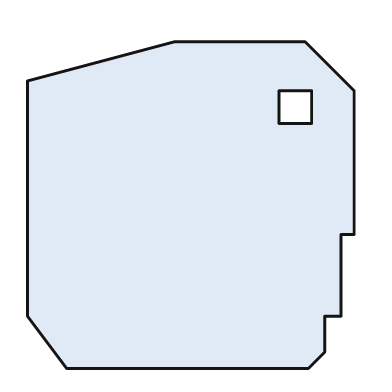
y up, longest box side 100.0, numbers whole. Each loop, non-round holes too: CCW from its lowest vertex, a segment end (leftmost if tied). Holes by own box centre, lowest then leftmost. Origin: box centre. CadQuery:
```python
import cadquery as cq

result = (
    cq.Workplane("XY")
    .moveTo(-38.0, -50.0)
    .lineTo(36.0, -50.0)
    .lineTo(41.0, -45.0)
    .lineTo(41.0, -34.0)
    .lineTo(46.0, -34.0)
    .lineTo(46.0, -9.0)
    .lineTo(50.0, -9.0)
    .lineTo(50.0, 35.0)
    .lineTo(35.0, 50.0)
    .lineTo(-5.0, 50.0)
    .lineTo(-50.0, 38.0)
    .lineTo(-50.0, -34.0)
    .close()
    .moveTo(27.0, 25.0)
    .lineTo(37.0, 25.0)
    .lineTo(37.0, 35.0)
    .lineTo(27.0, 35.0)
    .close()
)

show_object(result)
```